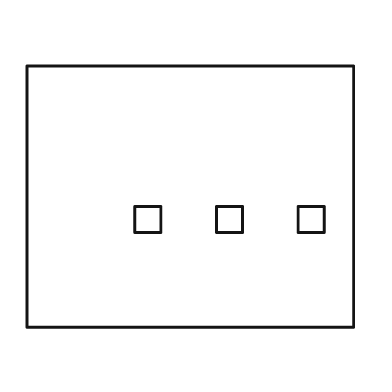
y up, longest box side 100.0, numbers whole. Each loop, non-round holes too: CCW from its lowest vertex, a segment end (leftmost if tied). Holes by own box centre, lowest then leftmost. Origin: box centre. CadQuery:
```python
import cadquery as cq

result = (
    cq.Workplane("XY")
    .moveTo(-50.0, -40.0)
    .lineTo(50.0, -40.0)
    .lineTo(50.0, 40.0)
    .lineTo(-50.0, 40.0)
    .close()
    .moveTo(-17.0, -11.0)
    .lineTo(-9.0, -11.0)
    .lineTo(-9.0, -3.0)
    .lineTo(-17.0, -3.0)
    .close()
    .moveTo(8.0, -11.0)
    .lineTo(16.0, -11.0)
    .lineTo(16.0, -3.0)
    .lineTo(8.0, -3.0)
    .close()
    .moveTo(33.0, -11.0)
    .lineTo(41.0, -11.0)
    .lineTo(41.0, -3.0)
    .lineTo(33.0, -3.0)
    .close()
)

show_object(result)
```